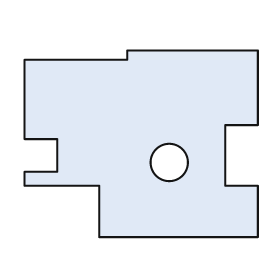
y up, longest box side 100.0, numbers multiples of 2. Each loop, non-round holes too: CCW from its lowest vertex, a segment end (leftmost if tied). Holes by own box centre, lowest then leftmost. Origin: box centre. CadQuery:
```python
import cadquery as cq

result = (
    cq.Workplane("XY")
    .moveTo(-18.0, -40.0)
    .lineTo(50.0, -40.0)
    .lineTo(50.0, -18.0)
    .lineTo(36.0, -18.0)
    .lineTo(36.0, 8.0)
    .lineTo(50.0, 8.0)
    .lineTo(50.0, 40.0)
    .lineTo(-6.0, 40.0)
    .lineTo(-6.0, 36.0)
    .lineTo(-50.0, 36.0)
    .lineTo(-50.0, 2.0)
    .lineTo(-36.0, 2.0)
    .lineTo(-36.0, -12.0)
    .lineTo(-50.0, -12.0)
    .lineTo(-50.0, -18.0)
    .lineTo(-18.0, -18.0)
    .close()
    .moveTo(12.0, -8.0)
    .circle(8.0)
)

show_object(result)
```